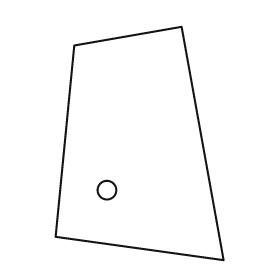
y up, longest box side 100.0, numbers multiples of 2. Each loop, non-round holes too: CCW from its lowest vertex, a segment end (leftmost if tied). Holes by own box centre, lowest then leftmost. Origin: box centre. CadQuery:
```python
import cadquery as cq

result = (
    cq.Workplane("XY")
    .moveTo(36.0, -50.0)
    .lineTo(18.0, 50.0)
    .lineTo(-28.0, 42.0)
    .lineTo(-36.0, -40.0)
    .close()
    .moveTo(-14.0, -20.0)
    .circle(4.0)
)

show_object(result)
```